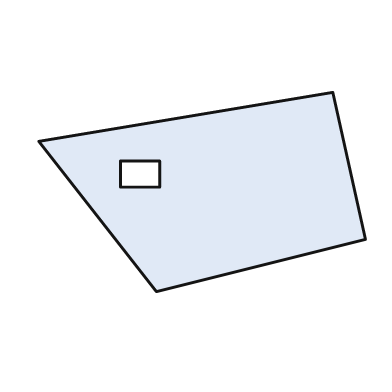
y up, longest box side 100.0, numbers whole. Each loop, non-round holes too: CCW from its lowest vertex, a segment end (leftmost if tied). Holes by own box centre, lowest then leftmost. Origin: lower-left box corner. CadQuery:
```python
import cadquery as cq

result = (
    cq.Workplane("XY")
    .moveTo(36.0, 0.0)
    .lineTo(100.0, 16.0)
    .lineTo(90.0, 61.0)
    .lineTo(0.0, 46.0)
    .close()
    .moveTo(25.0, 32.0)
    .lineTo(37.0, 32.0)
    .lineTo(37.0, 40.0)
    .lineTo(25.0, 40.0)
    .close()
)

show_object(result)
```